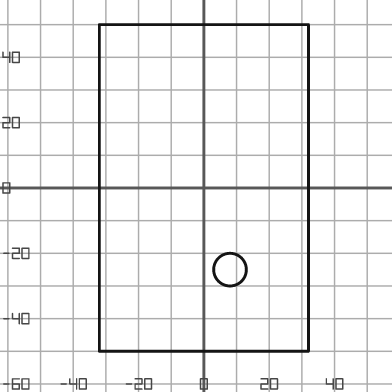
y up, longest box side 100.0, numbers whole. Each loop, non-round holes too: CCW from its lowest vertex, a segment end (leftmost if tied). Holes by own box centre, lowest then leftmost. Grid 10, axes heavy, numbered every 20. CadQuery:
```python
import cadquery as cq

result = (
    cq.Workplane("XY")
    .moveTo(-32.0, -50.0)
    .lineTo(32.0, -50.0)
    .lineTo(32.0, 50.0)
    .lineTo(-32.0, 50.0)
    .close()
    .moveTo(8.0, -25.0)
    .circle(5.0)
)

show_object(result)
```